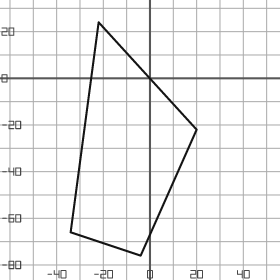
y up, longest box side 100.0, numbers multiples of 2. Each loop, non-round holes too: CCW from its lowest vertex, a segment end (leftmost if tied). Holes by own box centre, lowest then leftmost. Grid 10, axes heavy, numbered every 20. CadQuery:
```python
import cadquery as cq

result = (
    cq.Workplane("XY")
    .moveTo(-4.0, -76.0)
    .lineTo(20.0, -22.0)
    .lineTo(-22.0, 24.0)
    .lineTo(-34.0, -66.0)
    .close()
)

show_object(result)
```